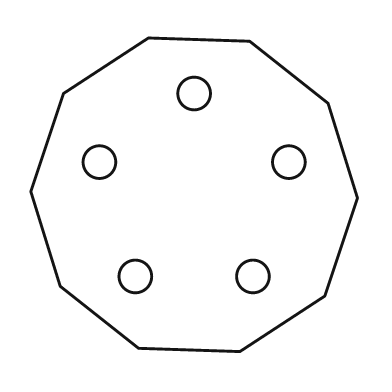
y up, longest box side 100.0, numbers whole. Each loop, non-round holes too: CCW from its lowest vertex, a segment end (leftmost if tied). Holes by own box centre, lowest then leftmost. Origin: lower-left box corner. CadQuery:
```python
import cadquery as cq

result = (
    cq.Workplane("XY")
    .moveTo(64.0, 0.0)
    .lineTo(90.0, 17.0)
    .lineTo(100.0, 47.0)
    .lineTo(91.0, 76.0)
    .lineTo(67.0, 95.0)
    .lineTo(36.0, 96.0)
    .lineTo(10.0, 79.0)
    .lineTo(0.0, 49.0)
    .lineTo(9.0, 20.0)
    .lineTo(33.0, 1.0)
    .close()
    .moveTo(32.0, 23.0)
    .circle(5.0)
    .moveTo(68.0, 23.0)
    .circle(5.0)
    .moveTo(21.0, 58.0)
    .circle(5.0)
    .moveTo(79.0, 58.0)
    .circle(5.0)
    .moveTo(50.0, 79.0)
    .circle(5.0)
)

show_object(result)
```